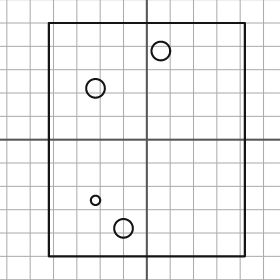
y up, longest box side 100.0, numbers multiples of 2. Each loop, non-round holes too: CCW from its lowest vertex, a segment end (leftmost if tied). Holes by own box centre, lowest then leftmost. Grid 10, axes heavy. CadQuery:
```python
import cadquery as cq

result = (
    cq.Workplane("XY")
    .moveTo(-42.0, -50.0)
    .lineTo(42.0, -50.0)
    .lineTo(42.0, 50.0)
    .lineTo(-42.0, 50.0)
    .close()
    .moveTo(-10.0, -38.0)
    .circle(4.0)
    .moveTo(-22.0, -26.0)
    .circle(2.0)
    .moveTo(-22.0, 22.0)
    .circle(4.0)
    .moveTo(6.0, 38.0)
    .circle(4.0)
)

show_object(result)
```